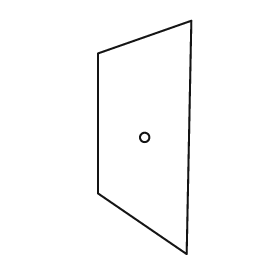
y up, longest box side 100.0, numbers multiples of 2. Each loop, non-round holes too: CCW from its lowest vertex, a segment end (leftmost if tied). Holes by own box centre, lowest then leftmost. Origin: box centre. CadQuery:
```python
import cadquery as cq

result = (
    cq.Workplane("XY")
    .moveTo(18.0, -50.0)
    .lineTo(20.0, 50.0)
    .lineTo(-20.0, 36.0)
    .lineTo(-20.0, -24.0)
    .close()
    .moveTo(0.0, 0.0)
    .circle(2.0)
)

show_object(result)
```